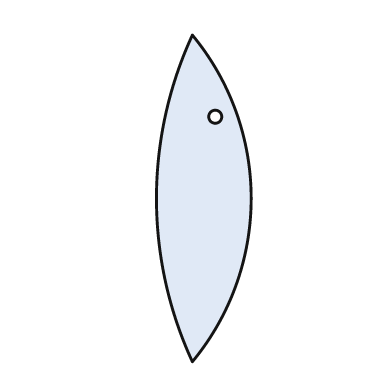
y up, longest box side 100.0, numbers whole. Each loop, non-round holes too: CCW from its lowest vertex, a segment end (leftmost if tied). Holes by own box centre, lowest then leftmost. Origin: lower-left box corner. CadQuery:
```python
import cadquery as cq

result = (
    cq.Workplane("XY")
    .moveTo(11.0, 0.0)
    .threePointArc((29.0, 50.0), (11.0, 100.0))
    .threePointArc((0.0, 50.0), (11.0, 0.0))
    .close()
    .moveTo(18.0, 75.0)
    .circle(2.0)
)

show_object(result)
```